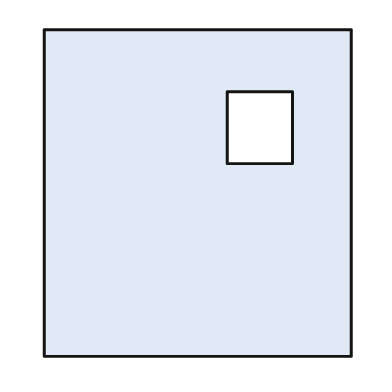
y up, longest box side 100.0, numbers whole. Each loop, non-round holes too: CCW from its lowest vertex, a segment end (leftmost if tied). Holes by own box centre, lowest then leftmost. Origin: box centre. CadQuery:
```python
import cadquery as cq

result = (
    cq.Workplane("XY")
    .moveTo(-47.0, -50.0)
    .lineTo(47.0, -50.0)
    .lineTo(47.0, 50.0)
    .lineTo(-47.0, 50.0)
    .close()
    .moveTo(9.0, 9.0)
    .lineTo(29.0, 9.0)
    .lineTo(29.0, 31.0)
    .lineTo(9.0, 31.0)
    .close()
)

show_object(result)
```